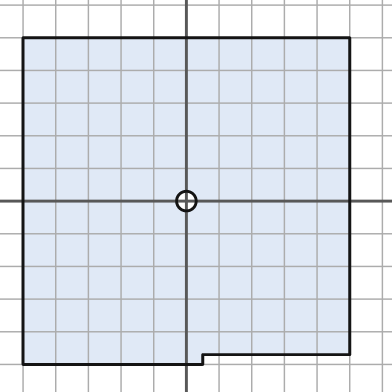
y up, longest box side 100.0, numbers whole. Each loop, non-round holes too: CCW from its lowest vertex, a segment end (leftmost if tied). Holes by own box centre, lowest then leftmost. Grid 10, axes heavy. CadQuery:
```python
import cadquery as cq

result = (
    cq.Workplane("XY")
    .moveTo(-50.0, -50.0)
    .lineTo(5.0, -50.0)
    .lineTo(5.0, -47.0)
    .lineTo(50.0, -47.0)
    .lineTo(50.0, 50.0)
    .lineTo(-50.0, 50.0)
    .close()
    .moveTo(0.0, 0.0)
    .circle(3.0)
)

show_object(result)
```